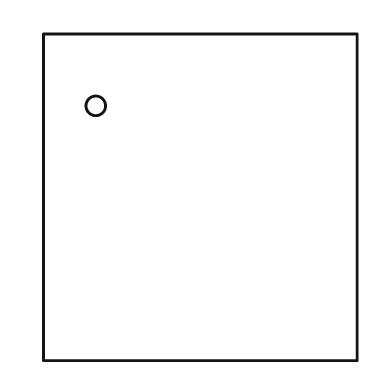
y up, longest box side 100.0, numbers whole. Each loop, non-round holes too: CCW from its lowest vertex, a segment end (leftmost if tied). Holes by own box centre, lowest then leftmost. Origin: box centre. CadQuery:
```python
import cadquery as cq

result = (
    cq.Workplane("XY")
    .moveTo(-48.0, -50.0)
    .lineTo(48.0, -50.0)
    .lineTo(48.0, 50.0)
    .lineTo(-48.0, 50.0)
    .close()
    .moveTo(-32.0, 28.0)
    .circle(3.0)
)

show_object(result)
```